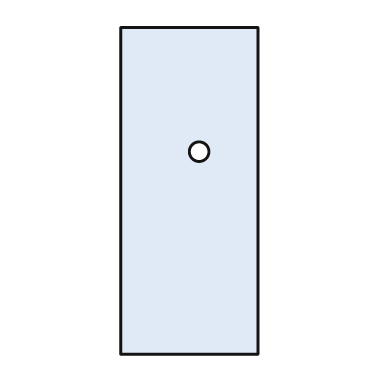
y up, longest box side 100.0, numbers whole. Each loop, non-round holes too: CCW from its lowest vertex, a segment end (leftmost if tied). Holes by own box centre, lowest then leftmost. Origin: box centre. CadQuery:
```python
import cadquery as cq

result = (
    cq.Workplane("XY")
    .moveTo(-21.0, -50.0)
    .lineTo(21.0, -50.0)
    .lineTo(21.0, 50.0)
    .lineTo(-21.0, 50.0)
    .close()
    .moveTo(3.0, 12.0)
    .circle(3.0)
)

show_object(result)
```